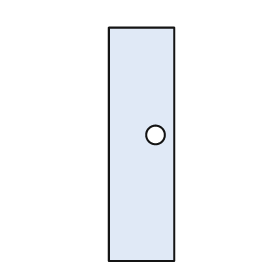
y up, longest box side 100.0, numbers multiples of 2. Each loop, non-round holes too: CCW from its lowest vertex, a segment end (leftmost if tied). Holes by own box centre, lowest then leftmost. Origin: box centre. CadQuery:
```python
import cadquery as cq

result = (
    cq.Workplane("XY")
    .moveTo(-14.0, -50.0)
    .lineTo(14.0, -50.0)
    .lineTo(14.0, 50.0)
    .lineTo(-14.0, 50.0)
    .close()
    .moveTo(6.0, 4.0)
    .circle(4.0)
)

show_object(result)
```